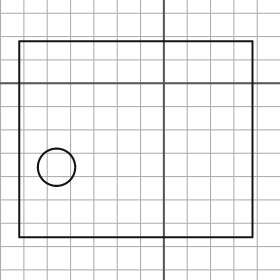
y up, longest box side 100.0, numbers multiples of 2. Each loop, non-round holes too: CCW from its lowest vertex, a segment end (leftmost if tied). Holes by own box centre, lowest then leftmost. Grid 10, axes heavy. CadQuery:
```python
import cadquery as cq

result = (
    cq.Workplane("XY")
    .moveTo(-62.0, -66.0)
    .lineTo(38.0, -66.0)
    .lineTo(38.0, 18.0)
    .lineTo(-62.0, 18.0)
    .close()
    .moveTo(-46.0, -36.0)
    .circle(8.0)
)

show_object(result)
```